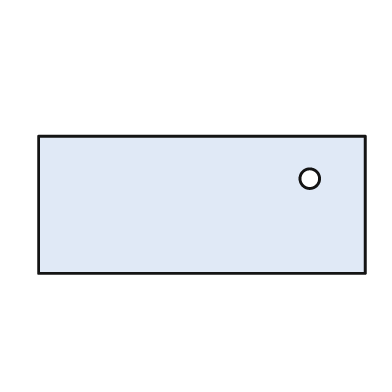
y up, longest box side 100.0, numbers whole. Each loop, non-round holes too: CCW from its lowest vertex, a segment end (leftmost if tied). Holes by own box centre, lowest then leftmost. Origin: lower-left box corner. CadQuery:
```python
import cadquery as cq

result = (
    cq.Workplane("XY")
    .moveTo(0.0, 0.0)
    .lineTo(100.0, 0.0)
    .lineTo(100.0, 42.0)
    .lineTo(0.0, 42.0)
    .close()
    .moveTo(83.0, 29.0)
    .circle(3.0)
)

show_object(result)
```